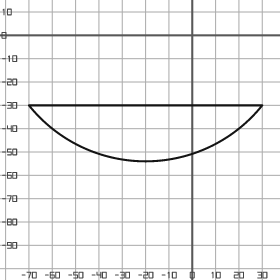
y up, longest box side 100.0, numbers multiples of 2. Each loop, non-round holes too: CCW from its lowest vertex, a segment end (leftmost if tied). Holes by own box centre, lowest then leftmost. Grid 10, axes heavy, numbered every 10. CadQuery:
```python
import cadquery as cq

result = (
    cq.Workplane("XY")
    .moveTo(-70.0, -30.0)
    .threePointArc((-20.0, -54.0), (30.0, -30.0))
    .close()
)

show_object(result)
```